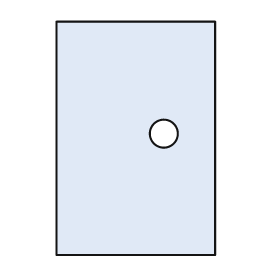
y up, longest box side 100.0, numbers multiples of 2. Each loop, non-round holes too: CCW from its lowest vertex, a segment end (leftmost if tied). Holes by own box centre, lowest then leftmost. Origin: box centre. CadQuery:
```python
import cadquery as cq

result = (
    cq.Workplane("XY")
    .moveTo(-34.0, -50.0)
    .lineTo(34.0, -50.0)
    .lineTo(34.0, 50.0)
    .lineTo(-34.0, 50.0)
    .close()
    .moveTo(12.0, 2.0)
    .circle(6.0)
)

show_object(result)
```